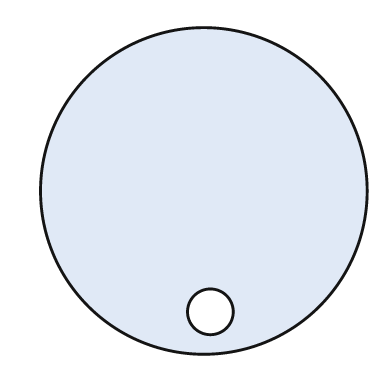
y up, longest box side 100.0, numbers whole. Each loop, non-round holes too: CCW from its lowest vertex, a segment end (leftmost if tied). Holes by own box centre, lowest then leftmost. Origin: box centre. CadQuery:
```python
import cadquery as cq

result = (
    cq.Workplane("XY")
    .moveTo(0.0, 0.0)
    .circle(50.0)
    .moveTo(2.0, -37.0)
    .circle(7.0)
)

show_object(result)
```